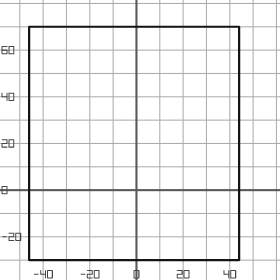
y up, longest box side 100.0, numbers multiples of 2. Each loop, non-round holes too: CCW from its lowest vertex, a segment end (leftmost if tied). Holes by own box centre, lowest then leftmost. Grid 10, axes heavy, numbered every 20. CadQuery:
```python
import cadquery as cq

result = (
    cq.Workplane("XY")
    .moveTo(-46.0, -30.0)
    .lineTo(44.0, -30.0)
    .lineTo(44.0, 70.0)
    .lineTo(-46.0, 70.0)
    .close()
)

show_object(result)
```